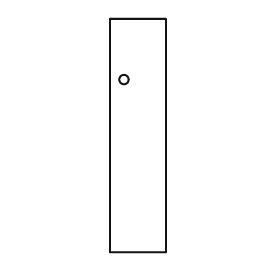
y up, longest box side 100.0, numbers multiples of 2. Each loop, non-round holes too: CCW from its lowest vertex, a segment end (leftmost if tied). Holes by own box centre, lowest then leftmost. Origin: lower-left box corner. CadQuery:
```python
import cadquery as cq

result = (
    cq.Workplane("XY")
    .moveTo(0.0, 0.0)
    .lineTo(24.0, 0.0)
    .lineTo(24.0, 100.0)
    .lineTo(0.0, 100.0)
    .close()
    .moveTo(6.0, 74.0)
    .circle(2.0)
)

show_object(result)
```